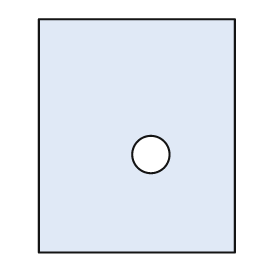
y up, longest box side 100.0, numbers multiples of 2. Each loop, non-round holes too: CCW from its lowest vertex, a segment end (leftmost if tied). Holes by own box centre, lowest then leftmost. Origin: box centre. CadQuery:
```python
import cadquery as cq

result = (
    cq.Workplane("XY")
    .moveTo(-42.0, -50.0)
    .lineTo(42.0, -50.0)
    .lineTo(42.0, 50.0)
    .lineTo(-42.0, 50.0)
    .close()
    .moveTo(6.0, -8.0)
    .circle(8.0)
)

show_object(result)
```